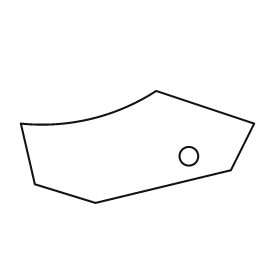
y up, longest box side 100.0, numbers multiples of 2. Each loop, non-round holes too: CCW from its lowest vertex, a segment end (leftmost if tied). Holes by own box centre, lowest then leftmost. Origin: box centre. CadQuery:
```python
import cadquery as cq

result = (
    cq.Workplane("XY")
    .moveTo(-18.0, -24.0)
    .lineTo(40.0, -10.0)
    .lineTo(50.0, 10.0)
    .lineTo(8.0, 24.0)
    .threePointArc((-20.0, 12.0), (-50.0, 10.0))
    .lineTo(-44.0, -16.0)
    .close()
    .moveTo(22.0, -4.0)
    .circle(4.0)
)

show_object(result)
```